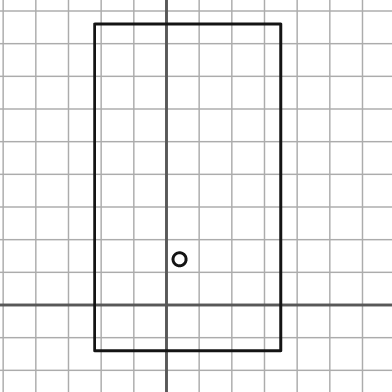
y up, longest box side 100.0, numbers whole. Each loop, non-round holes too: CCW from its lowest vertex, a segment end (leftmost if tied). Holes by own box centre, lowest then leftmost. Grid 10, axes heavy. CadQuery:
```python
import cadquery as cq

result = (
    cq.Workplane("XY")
    .moveTo(-22.0, -14.0)
    .lineTo(35.0, -14.0)
    .lineTo(35.0, 86.0)
    .lineTo(-22.0, 86.0)
    .close()
    .moveTo(4.0, 14.0)
    .circle(2.0)
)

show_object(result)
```